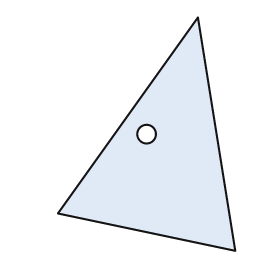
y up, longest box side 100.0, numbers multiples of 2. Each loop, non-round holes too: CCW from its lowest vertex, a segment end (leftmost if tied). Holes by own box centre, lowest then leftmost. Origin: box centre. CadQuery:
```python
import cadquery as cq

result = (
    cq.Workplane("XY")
    .moveTo(38.0, -50.0)
    .lineTo(22.0, 50.0)
    .lineTo(-38.0, -34.0)
    .close()
    .moveTo(0.0, 0.0)
    .circle(4.0)
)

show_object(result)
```